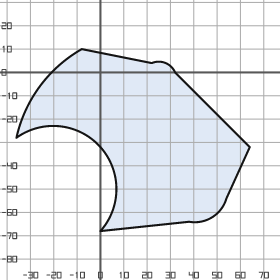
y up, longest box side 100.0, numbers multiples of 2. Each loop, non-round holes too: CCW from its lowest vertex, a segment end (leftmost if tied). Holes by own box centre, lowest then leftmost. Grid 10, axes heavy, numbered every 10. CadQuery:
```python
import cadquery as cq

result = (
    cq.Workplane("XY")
    .moveTo(0.0, -68.0)
    .lineTo(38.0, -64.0)
    .threePointArc((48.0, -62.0), (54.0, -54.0))
    .lineTo(64.0, -32.0)
    .lineTo(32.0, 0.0)
    .threePointArc((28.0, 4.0), (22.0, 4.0))
    .lineTo(-8.0, 10.0)
    .threePointArc((-26.0, -6.0), (-36.0, -28.0))
    .threePointArc((0.0, -32.0), (0.0, -68.0))
    .close()
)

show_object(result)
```